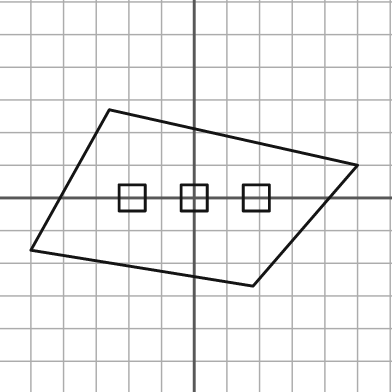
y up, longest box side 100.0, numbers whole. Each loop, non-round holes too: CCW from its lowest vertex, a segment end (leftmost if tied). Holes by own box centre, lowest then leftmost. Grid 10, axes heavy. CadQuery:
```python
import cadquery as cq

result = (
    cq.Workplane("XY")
    .moveTo(18.0, -27.0)
    .lineTo(50.0, 10.0)
    .lineTo(-26.0, 27.0)
    .lineTo(-50.0, -16.0)
    .close()
    .moveTo(-23.0, -4.0)
    .lineTo(-15.0, -4.0)
    .lineTo(-15.0, 4.0)
    .lineTo(-23.0, 4.0)
    .close()
    .moveTo(-4.0, -4.0)
    .lineTo(4.0, -4.0)
    .lineTo(4.0, 4.0)
    .lineTo(-4.0, 4.0)
    .close()
    .moveTo(15.0, -4.0)
    .lineTo(23.0, -4.0)
    .lineTo(23.0, 4.0)
    .lineTo(15.0, 4.0)
    .close()
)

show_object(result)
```